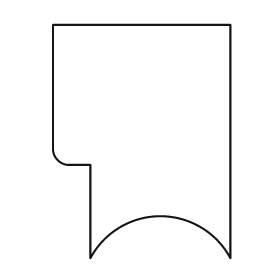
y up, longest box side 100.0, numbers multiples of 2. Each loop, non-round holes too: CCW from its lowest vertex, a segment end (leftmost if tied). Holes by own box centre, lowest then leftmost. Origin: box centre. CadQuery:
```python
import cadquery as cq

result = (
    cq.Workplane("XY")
    .moveTo(-22.0, -50.0)
    .threePointArc((8.0, -32.0), (38.0, -50.0))
    .lineTo(38.0, 50.0)
    .lineTo(-38.0, 50.0)
    .lineTo(-38.0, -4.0)
    .threePointArc((-36.0, -8.0), (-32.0, -10.0))
    .lineTo(-22.0, -10.0)
    .close()
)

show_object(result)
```